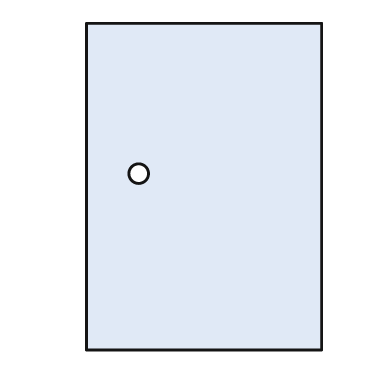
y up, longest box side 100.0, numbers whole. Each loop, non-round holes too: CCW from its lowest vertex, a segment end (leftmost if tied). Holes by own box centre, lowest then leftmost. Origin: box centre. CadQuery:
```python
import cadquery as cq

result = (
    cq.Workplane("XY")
    .moveTo(-36.0, -50.0)
    .lineTo(36.0, -50.0)
    .lineTo(36.0, 50.0)
    .lineTo(-36.0, 50.0)
    .close()
    .moveTo(-20.0, 4.0)
    .circle(3.0)
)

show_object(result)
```